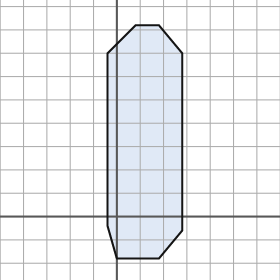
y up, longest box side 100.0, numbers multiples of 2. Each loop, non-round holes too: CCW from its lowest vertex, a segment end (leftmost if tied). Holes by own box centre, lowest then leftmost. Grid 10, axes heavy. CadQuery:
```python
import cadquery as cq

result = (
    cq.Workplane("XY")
    .moveTo(0.0, -18.0)
    .lineTo(18.0, -18.0)
    .lineTo(28.0, -6.0)
    .lineTo(28.0, 70.0)
    .lineTo(18.0, 82.0)
    .lineTo(8.0, 82.0)
    .lineTo(-4.0, 70.0)
    .lineTo(-4.0, -4.0)
    .close()
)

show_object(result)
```